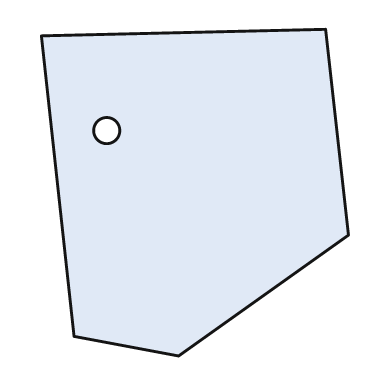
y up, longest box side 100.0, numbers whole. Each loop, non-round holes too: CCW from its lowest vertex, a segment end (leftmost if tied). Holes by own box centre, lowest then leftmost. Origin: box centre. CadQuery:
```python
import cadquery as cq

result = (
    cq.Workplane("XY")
    .moveTo(-5.0, -50.0)
    .lineTo(47.0, -13.0)
    .lineTo(40.0, 50.0)
    .lineTo(-47.0, 48.0)
    .lineTo(-37.0, -44.0)
    .close()
    .moveTo(-27.0, 19.0)
    .circle(4.0)
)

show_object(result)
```